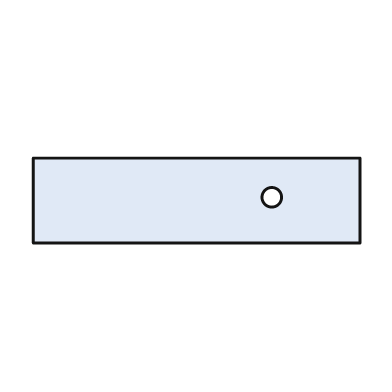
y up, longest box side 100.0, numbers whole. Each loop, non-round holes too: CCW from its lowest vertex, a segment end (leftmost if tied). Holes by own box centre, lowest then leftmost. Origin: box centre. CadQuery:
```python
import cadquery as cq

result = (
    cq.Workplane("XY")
    .moveTo(-50.0, -13.0)
    .lineTo(50.0, -13.0)
    .lineTo(50.0, 13.0)
    .lineTo(-50.0, 13.0)
    .close()
    .moveTo(23.0, 1.0)
    .circle(3.0)
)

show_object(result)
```